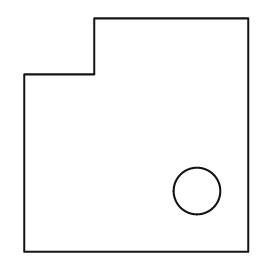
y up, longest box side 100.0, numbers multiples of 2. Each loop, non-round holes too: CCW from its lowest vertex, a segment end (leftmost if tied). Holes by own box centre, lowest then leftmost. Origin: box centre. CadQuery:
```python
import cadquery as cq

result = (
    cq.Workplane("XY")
    .moveTo(-48.0, -50.0)
    .lineTo(48.0, -50.0)
    .lineTo(48.0, 50.0)
    .lineTo(-18.0, 50.0)
    .lineTo(-18.0, 26.0)
    .lineTo(-48.0, 26.0)
    .close()
    .moveTo(26.0, -24.0)
    .circle(10.0)
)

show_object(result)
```